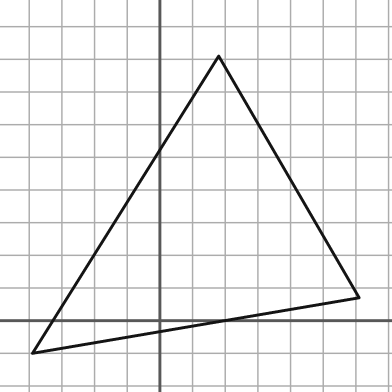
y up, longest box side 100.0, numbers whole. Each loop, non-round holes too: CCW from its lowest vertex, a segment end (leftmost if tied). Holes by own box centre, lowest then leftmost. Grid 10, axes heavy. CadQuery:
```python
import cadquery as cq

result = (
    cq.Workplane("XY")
    .moveTo(-39.0, -10.0)
    .lineTo(61.0, 7.0)
    .lineTo(18.0, 81.0)
    .close()
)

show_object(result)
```